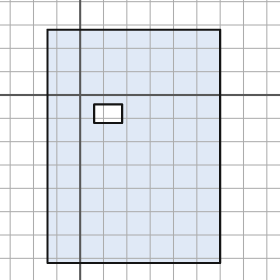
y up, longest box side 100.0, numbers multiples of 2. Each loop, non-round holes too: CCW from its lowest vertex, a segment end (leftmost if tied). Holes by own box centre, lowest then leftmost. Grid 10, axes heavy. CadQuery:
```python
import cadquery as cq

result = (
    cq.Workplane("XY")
    .moveTo(-14.0, -72.0)
    .lineTo(60.0, -72.0)
    .lineTo(60.0, 28.0)
    .lineTo(-14.0, 28.0)
    .close()
    .moveTo(6.0, -12.0)
    .lineTo(18.0, -12.0)
    .lineTo(18.0, -4.0)
    .lineTo(6.0, -4.0)
    .close()
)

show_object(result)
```